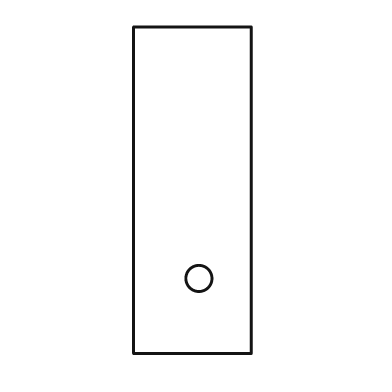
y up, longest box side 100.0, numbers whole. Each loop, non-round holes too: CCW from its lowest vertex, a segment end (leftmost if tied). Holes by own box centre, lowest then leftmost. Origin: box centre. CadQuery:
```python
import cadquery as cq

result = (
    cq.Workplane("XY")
    .moveTo(-18.0, -50.0)
    .lineTo(18.0, -50.0)
    .lineTo(18.0, 50.0)
    .lineTo(-18.0, 50.0)
    .close()
    .moveTo(2.0, -27.0)
    .circle(4.0)
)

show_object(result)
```